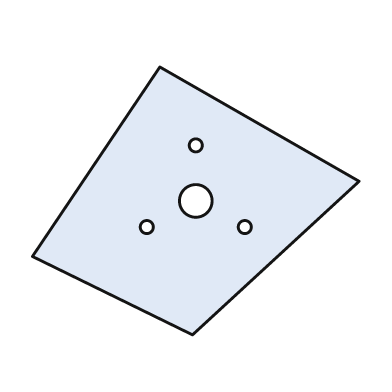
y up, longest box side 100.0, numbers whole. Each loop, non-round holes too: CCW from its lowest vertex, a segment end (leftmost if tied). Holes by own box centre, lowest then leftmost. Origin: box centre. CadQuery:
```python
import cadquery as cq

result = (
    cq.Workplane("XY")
    .moveTo(-1.0, -41.0)
    .lineTo(50.0, 6.0)
    .lineTo(-11.0, 41.0)
    .lineTo(-50.0, -17.0)
    .close()
    .moveTo(-15.0, -8.0)
    .circle(2.0)
    .moveTo(15.0, -8.0)
    .circle(2.0)
    .moveTo(0.0, 0.0)
    .circle(5.0)
    .moveTo(0.0, 17.0)
    .circle(2.0)
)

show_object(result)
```